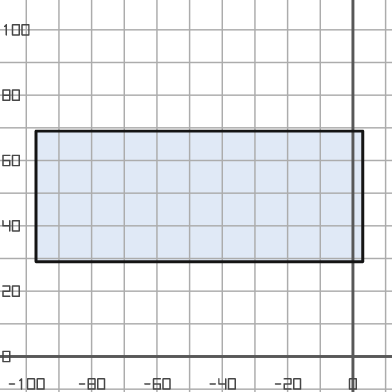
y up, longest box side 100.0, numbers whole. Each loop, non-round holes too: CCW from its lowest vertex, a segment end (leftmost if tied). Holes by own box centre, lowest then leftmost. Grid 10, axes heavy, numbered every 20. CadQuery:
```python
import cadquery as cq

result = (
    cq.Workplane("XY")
    .moveTo(-97.0, 29.0)
    .lineTo(3.0, 29.0)
    .lineTo(3.0, 69.0)
    .lineTo(-97.0, 69.0)
    .close()
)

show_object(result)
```